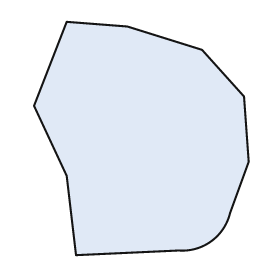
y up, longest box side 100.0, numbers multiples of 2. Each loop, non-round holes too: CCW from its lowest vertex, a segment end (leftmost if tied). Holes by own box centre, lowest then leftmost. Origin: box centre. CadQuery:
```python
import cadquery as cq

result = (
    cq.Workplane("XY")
    .moveTo(-28.0, -50.0)
    .lineTo(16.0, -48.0)
    .threePointArc((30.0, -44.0), (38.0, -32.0))
    .lineTo(46.0, -10.0)
    .lineTo(44.0, 18.0)
    .lineTo(26.0, 38.0)
    .lineTo(-6.0, 48.0)
    .lineTo(-32.0, 50.0)
    .lineTo(-46.0, 14.0)
    .lineTo(-32.0, -16.0)
    .close()
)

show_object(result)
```